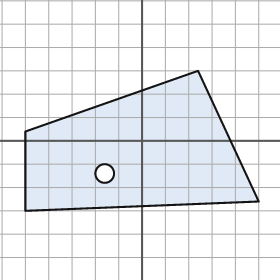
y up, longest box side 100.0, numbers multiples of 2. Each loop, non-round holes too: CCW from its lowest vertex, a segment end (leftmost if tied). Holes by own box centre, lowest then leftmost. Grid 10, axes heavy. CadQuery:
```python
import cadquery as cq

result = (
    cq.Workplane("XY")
    .moveTo(-50.0, -30.0)
    .lineTo(50.0, -26.0)
    .lineTo(24.0, 30.0)
    .lineTo(-50.0, 4.0)
    .close()
    .moveTo(-16.0, -14.0)
    .circle(4.0)
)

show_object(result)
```